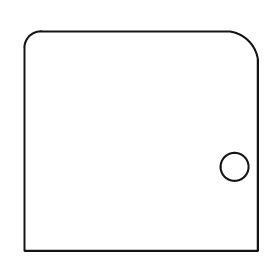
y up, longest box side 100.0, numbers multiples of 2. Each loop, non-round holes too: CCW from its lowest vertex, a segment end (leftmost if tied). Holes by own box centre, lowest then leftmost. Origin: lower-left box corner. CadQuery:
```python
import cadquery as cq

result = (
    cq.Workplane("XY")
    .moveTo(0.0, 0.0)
    .lineTo(100.0, 0.0)
    .lineTo(100.0, 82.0)
    .threePointArc((96.0, 90.0), (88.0, 94.0))
    .lineTo(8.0, 94.0)
    .threePointArc((2.0, 92.0), (0.0, 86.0))
    .close()
    .moveTo(90.0, 36.0)
    .circle(6.0)
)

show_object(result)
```